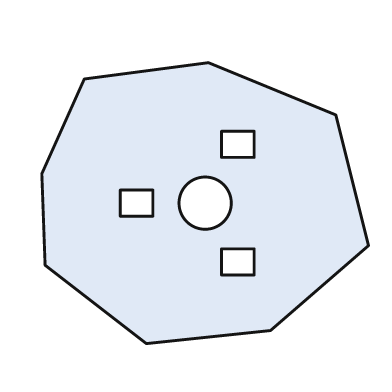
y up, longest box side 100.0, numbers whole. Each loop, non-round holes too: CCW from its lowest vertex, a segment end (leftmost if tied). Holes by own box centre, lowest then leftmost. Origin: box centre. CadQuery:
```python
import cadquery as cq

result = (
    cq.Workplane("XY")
    .moveTo(-18.0, -43.0)
    .lineTo(20.0, -39.0)
    .lineTo(50.0, -13.0)
    .lineTo(40.0, 27.0)
    .lineTo(1.0, 43.0)
    .lineTo(-37.0, 38.0)
    .lineTo(-50.0, 9.0)
    .lineTo(-49.0, -19.0)
    .close()
    .moveTo(5.0, -22.0)
    .lineTo(15.0, -22.0)
    .lineTo(15.0, -14.0)
    .lineTo(5.0, -14.0)
    .close()
    .moveTo(-26.0, -4.0)
    .lineTo(-16.0, -4.0)
    .lineTo(-16.0, 4.0)
    .lineTo(-26.0, 4.0)
    .close()
    .moveTo(0.0, 0.0)
    .circle(8.0)
    .moveTo(5.0, 14.0)
    .lineTo(15.0, 14.0)
    .lineTo(15.0, 22.0)
    .lineTo(5.0, 22.0)
    .close()
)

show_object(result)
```